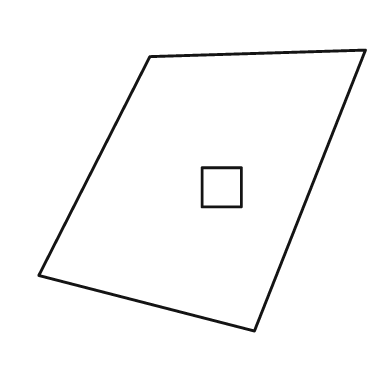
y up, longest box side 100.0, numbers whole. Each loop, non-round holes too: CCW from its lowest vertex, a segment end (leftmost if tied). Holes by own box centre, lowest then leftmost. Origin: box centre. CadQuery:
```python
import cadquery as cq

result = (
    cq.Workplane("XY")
    .moveTo(16.0, -43.0)
    .lineTo(50.0, 43.0)
    .lineTo(-16.0, 41.0)
    .lineTo(-50.0, -26.0)
    .close()
    .moveTo(0.0, -5.0)
    .lineTo(12.0, -5.0)
    .lineTo(12.0, 7.0)
    .lineTo(0.0, 7.0)
    .close()
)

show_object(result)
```